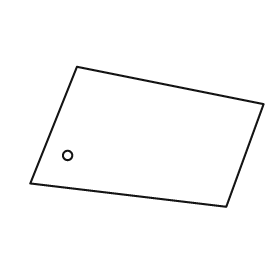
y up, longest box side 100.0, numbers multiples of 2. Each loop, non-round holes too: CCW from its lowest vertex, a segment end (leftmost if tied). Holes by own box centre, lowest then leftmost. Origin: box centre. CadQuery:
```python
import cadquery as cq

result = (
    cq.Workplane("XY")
    .moveTo(34.0, -30.0)
    .lineTo(50.0, 14.0)
    .lineTo(-30.0, 30.0)
    .lineTo(-50.0, -20.0)
    .close()
    .moveTo(-34.0, -8.0)
    .circle(2.0)
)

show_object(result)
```